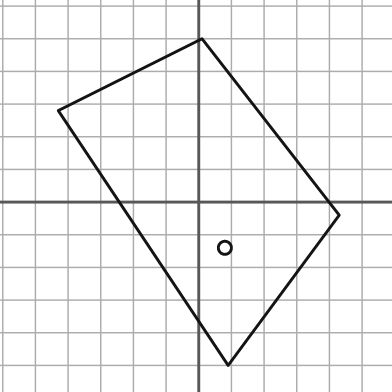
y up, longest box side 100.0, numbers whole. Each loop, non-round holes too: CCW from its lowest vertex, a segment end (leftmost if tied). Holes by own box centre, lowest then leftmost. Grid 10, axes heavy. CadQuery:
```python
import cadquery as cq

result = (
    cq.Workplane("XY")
    .moveTo(9.0, -50.0)
    .lineTo(43.0, -4.0)
    .lineTo(1.0, 50.0)
    .lineTo(-43.0, 28.0)
    .close()
    .moveTo(8.0, -14.0)
    .circle(2.0)
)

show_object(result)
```